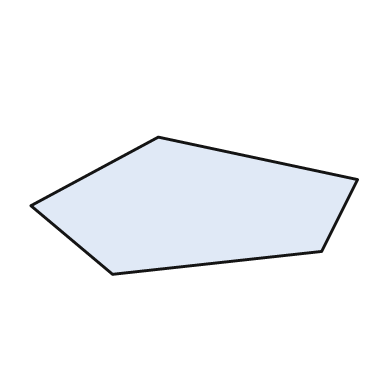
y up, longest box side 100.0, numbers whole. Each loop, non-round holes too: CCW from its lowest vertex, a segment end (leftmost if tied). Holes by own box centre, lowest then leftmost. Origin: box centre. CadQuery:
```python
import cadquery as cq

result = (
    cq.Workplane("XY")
    .moveTo(-25.0, -21.0)
    .lineTo(39.0, -14.0)
    .lineTo(50.0, 8.0)
    .lineTo(-11.0, 21.0)
    .lineTo(-50.0, 0.0)
    .close()
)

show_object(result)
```